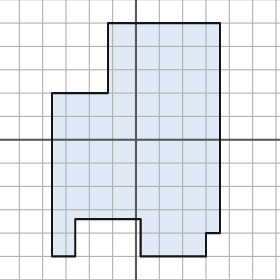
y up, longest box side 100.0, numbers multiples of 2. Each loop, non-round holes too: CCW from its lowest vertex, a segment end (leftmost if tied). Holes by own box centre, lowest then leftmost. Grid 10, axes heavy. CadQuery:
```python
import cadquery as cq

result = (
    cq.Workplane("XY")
    .moveTo(-36.0, -50.0)
    .lineTo(-26.0, -50.0)
    .lineTo(-26.0, -34.0)
    .lineTo(2.0, -34.0)
    .lineTo(2.0, -50.0)
    .lineTo(30.0, -50.0)
    .lineTo(30.0, -40.0)
    .lineTo(36.0, -40.0)
    .lineTo(36.0, 50.0)
    .lineTo(-12.0, 50.0)
    .lineTo(-12.0, 20.0)
    .lineTo(-36.0, 20.0)
    .close()
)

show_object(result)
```